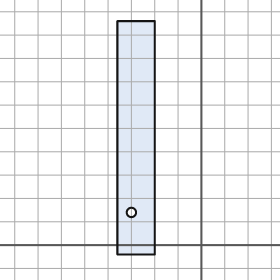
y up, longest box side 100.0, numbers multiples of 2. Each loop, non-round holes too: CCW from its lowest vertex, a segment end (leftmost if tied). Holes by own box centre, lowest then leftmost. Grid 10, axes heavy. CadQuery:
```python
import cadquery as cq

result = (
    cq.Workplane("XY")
    .moveTo(-36.0, -4.0)
    .lineTo(-20.0, -4.0)
    .lineTo(-20.0, 96.0)
    .lineTo(-36.0, 96.0)
    .close()
    .moveTo(-30.0, 14.0)
    .circle(2.0)
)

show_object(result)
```